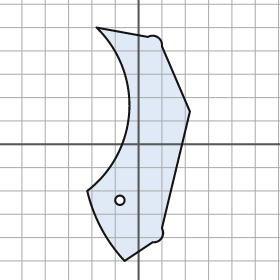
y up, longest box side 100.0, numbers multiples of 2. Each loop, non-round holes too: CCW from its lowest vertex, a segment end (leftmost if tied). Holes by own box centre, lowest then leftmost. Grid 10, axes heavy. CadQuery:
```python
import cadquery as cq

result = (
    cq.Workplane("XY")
    .moveTo(-6.0, -50.0)
    .lineTo(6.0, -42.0)
    .threePointArc((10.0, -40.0), (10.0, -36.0))
    .lineTo(22.0, 14.0)
    .lineTo(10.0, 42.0)
    .threePointArc((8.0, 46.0), (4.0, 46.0))
    .lineTo(-18.0, 50.0)
    .threePointArc((-4.0, 14.0), (-22.0, -20.0))
    .threePointArc((-16.0, -36.0), (-6.0, -50.0))
    .close()
    .moveTo(-8.0, -24.0)
    .circle(2.0)
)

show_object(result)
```